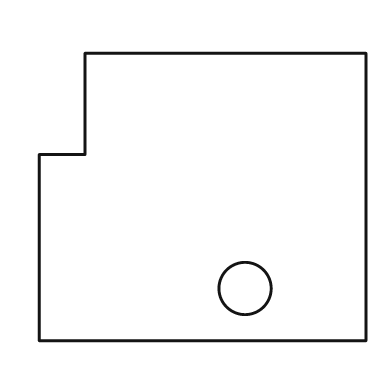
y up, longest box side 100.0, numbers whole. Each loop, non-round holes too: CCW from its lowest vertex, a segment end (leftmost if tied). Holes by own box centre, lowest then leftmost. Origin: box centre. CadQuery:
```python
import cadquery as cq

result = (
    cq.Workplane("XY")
    .moveTo(-50.0, -44.0)
    .lineTo(50.0, -44.0)
    .lineTo(50.0, 44.0)
    .lineTo(-36.0, 44.0)
    .lineTo(-36.0, 13.0)
    .lineTo(-50.0, 13.0)
    .close()
    .moveTo(13.0, -28.0)
    .circle(8.0)
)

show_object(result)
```